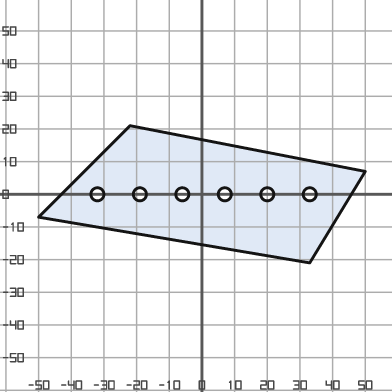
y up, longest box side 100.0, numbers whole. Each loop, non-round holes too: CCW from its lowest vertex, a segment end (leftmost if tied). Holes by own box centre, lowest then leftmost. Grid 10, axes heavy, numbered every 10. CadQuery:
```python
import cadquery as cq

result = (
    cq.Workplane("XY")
    .moveTo(33.0, -21.0)
    .lineTo(50.0, 7.0)
    .lineTo(-22.0, 21.0)
    .lineTo(-50.0, -7.0)
    .close()
    .moveTo(-32.0, 0.0)
    .circle(2.0)
    .moveTo(-19.0, 0.0)
    .circle(2.0)
    .moveTo(-6.0, 0.0)
    .circle(2.0)
    .moveTo(7.0, 0.0)
    .circle(2.0)
    .moveTo(20.0, 0.0)
    .circle(2.0)
    .moveTo(33.0, 0.0)
    .circle(2.0)
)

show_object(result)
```